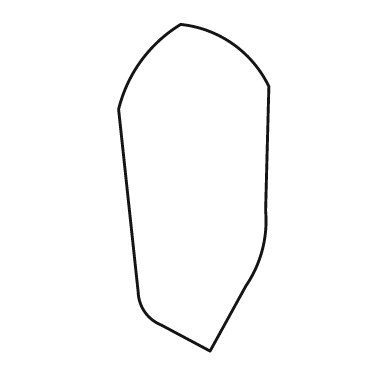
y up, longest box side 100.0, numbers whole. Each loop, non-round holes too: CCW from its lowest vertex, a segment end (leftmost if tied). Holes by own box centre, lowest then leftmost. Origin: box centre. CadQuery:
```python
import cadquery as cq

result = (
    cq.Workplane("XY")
    .moveTo(5.0, -50.0)
    .lineTo(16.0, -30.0)
    .threePointArc((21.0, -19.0), (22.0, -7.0))
    .lineTo(23.0, 31.0)
    .threePointArc((12.0, 44.0), (-4.0, 50.0))
    .threePointArc((-16.0, 39.0), (-23.0, 24.0))
    .lineTo(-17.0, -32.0)
    .threePointArc((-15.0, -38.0), (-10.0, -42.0))
    .close()
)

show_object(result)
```